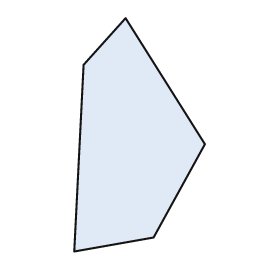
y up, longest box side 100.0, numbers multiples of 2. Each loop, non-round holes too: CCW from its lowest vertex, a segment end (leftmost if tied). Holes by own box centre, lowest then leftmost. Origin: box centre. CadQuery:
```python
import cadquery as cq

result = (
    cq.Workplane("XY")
    .moveTo(-28.0, -50.0)
    .lineTo(6.0, -44.0)
    .lineTo(28.0, -4.0)
    .lineTo(-6.0, 50.0)
    .lineTo(-24.0, 30.0)
    .close()
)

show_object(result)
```